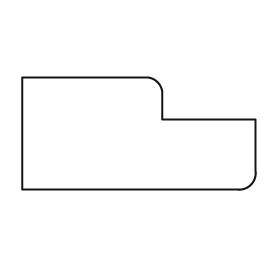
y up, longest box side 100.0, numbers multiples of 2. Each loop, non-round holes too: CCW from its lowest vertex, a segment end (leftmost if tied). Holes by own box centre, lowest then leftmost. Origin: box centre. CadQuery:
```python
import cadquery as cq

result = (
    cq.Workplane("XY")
    .moveTo(-50.0, -24.0)
    .lineTo(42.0, -24.0)
    .threePointArc((48.0, -22.0), (50.0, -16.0))
    .lineTo(50.0, 6.0)
    .lineTo(10.0, 6.0)
    .lineTo(10.0, 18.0)
    .threePointArc((8.0, 22.0), (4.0, 24.0))
    .lineTo(-50.0, 24.0)
    .close()
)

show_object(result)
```